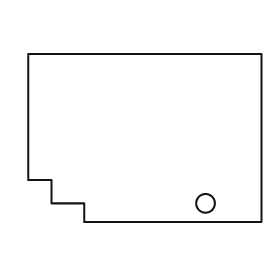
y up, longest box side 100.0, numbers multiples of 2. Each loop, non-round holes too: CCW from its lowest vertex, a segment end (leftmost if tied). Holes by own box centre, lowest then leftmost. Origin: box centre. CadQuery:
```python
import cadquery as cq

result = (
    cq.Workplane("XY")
    .moveTo(-26.0, -36.0)
    .lineTo(50.0, -36.0)
    .lineTo(50.0, 36.0)
    .lineTo(-50.0, 36.0)
    .lineTo(-50.0, -18.0)
    .lineTo(-40.0, -18.0)
    .lineTo(-40.0, -28.0)
    .lineTo(-26.0, -28.0)
    .close()
    .moveTo(26.0, -28.0)
    .circle(4.0)
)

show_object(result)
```